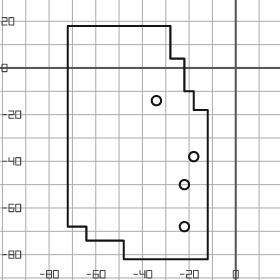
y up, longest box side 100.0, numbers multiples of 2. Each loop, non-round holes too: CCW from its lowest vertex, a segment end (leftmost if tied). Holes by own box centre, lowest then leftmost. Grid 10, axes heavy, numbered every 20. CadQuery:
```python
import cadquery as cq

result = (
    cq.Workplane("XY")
    .moveTo(-48.0, -82.0)
    .lineTo(-12.0, -82.0)
    .lineTo(-12.0, -18.0)
    .lineTo(-18.0, -18.0)
    .lineTo(-18.0, -10.0)
    .lineTo(-22.0, -10.0)
    .lineTo(-22.0, 4.0)
    .lineTo(-28.0, 4.0)
    .lineTo(-28.0, 18.0)
    .lineTo(-72.0, 18.0)
    .lineTo(-72.0, -68.0)
    .lineTo(-64.0, -68.0)
    .lineTo(-64.0, -74.0)
    .lineTo(-48.0, -74.0)
    .close()
    .moveTo(-22.0, -68.0)
    .circle(2.0)
    .moveTo(-22.0, -50.0)
    .circle(2.0)
    .moveTo(-18.0, -38.0)
    .circle(2.0)
    .moveTo(-34.0, -14.0)
    .circle(2.0)
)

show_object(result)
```